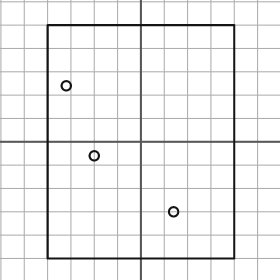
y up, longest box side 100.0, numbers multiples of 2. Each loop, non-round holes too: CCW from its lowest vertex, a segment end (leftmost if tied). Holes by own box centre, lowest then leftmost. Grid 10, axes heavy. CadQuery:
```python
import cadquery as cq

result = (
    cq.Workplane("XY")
    .moveTo(-40.0, -50.0)
    .lineTo(40.0, -50.0)
    .lineTo(40.0, 50.0)
    .lineTo(-40.0, 50.0)
    .close()
    .moveTo(14.0, -30.0)
    .circle(2.0)
    .moveTo(-20.0, -6.0)
    .circle(2.0)
    .moveTo(-32.0, 24.0)
    .circle(2.0)
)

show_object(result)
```